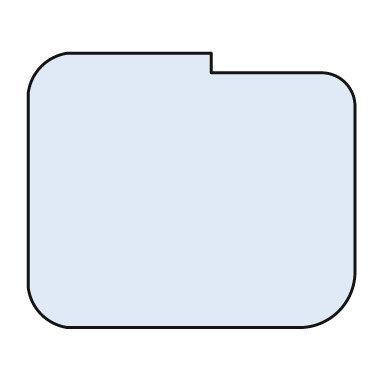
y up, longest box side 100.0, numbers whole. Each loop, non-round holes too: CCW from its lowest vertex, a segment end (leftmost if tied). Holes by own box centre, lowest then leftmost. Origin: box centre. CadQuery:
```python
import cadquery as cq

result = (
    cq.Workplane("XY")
    .moveTo(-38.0, -42.0)
    .lineTo(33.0, -42.0)
    .threePointArc((45.0, -37.0), (50.0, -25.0))
    .lineTo(50.0, 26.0)
    .threePointArc((47.0, 33.0), (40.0, 36.0))
    .lineTo(6.0, 36.0)
    .lineTo(6.0, 42.0)
    .lineTo(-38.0, 42.0)
    .threePointArc((-46.0, 38.0), (-50.0, 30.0))
    .lineTo(-50.0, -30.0)
    .threePointArc((-46.0, -38.0), (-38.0, -42.0))
    .close()
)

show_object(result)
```